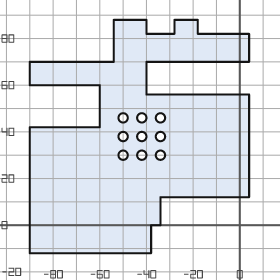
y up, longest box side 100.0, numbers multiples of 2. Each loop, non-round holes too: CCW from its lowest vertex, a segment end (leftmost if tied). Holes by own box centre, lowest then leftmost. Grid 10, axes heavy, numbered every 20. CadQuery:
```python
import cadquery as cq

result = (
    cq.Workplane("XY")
    .moveTo(-90.0, -12.0)
    .lineTo(-38.0, -12.0)
    .lineTo(-38.0, 0.0)
    .lineTo(-34.0, 0.0)
    .lineTo(-34.0, 12.0)
    .lineTo(4.0, 12.0)
    .lineTo(4.0, 56.0)
    .lineTo(-40.0, 56.0)
    .lineTo(-40.0, 70.0)
    .lineTo(4.0, 70.0)
    .lineTo(4.0, 82.0)
    .lineTo(-18.0, 82.0)
    .lineTo(-18.0, 88.0)
    .lineTo(-28.0, 88.0)
    .lineTo(-28.0, 82.0)
    .lineTo(-40.0, 82.0)
    .lineTo(-40.0, 88.0)
    .lineTo(-54.0, 88.0)
    .lineTo(-54.0, 70.0)
    .lineTo(-90.0, 70.0)
    .lineTo(-90.0, 60.0)
    .lineTo(-60.0, 60.0)
    .lineTo(-60.0, 42.0)
    .lineTo(-90.0, 42.0)
    .close()
    .moveTo(-50.0, 30.0)
    .circle(2.0)
    .moveTo(-42.0, 30.0)
    .circle(2.0)
    .moveTo(-34.0, 30.0)
    .circle(2.0)
    .moveTo(-50.0, 38.0)
    .circle(2.0)
    .moveTo(-42.0, 38.0)
    .circle(2.0)
    .moveTo(-34.0, 38.0)
    .circle(2.0)
    .moveTo(-50.0, 46.0)
    .circle(2.0)
    .moveTo(-42.0, 46.0)
    .circle(2.0)
    .moveTo(-34.0, 46.0)
    .circle(2.0)
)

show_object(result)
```